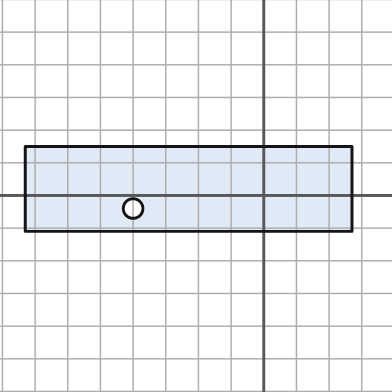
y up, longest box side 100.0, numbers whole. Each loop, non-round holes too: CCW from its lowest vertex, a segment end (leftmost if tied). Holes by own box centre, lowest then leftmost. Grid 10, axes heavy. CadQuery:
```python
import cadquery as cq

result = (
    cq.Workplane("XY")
    .moveTo(-73.0, -11.0)
    .lineTo(27.0, -11.0)
    .lineTo(27.0, 15.0)
    .lineTo(-73.0, 15.0)
    .close()
    .moveTo(-40.0, -4.0)
    .circle(3.0)
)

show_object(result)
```